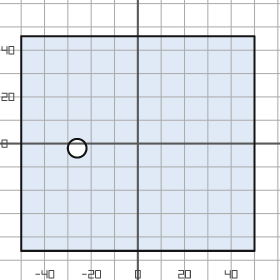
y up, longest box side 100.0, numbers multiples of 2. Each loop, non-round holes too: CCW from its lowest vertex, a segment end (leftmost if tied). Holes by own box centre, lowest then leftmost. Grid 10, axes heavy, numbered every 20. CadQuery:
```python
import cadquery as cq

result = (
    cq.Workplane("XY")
    .moveTo(-50.0, -46.0)
    .lineTo(50.0, -46.0)
    .lineTo(50.0, 46.0)
    .lineTo(-50.0, 46.0)
    .close()
    .moveTo(-26.0, -2.0)
    .circle(4.0)
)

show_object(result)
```